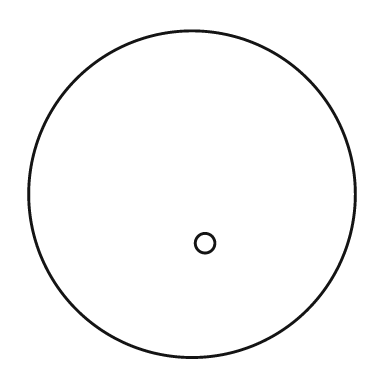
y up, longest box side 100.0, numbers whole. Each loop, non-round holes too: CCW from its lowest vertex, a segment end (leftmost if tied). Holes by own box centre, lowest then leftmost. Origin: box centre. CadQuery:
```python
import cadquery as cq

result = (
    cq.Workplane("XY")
    .moveTo(0.0, 0.0)
    .circle(50.0)
    .moveTo(4.0, -15.0)
    .circle(3.0)
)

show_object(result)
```